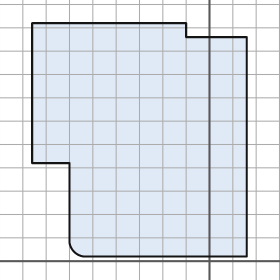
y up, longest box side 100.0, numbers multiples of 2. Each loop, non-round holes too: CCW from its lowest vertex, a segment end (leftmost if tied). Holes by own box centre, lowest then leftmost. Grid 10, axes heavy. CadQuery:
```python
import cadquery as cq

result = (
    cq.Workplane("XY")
    .moveTo(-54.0, 2.0)
    .lineTo(16.0, 2.0)
    .lineTo(16.0, 96.0)
    .lineTo(-10.0, 96.0)
    .lineTo(-10.0, 102.0)
    .lineTo(-76.0, 102.0)
    .lineTo(-76.0, 42.0)
    .lineTo(-60.0, 42.0)
    .lineTo(-60.0, 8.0)
    .threePointArc((-58.0, 4.0), (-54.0, 2.0))
    .close()
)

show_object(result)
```